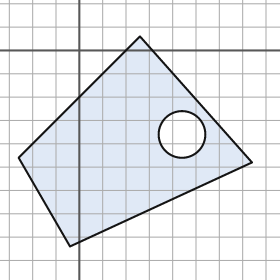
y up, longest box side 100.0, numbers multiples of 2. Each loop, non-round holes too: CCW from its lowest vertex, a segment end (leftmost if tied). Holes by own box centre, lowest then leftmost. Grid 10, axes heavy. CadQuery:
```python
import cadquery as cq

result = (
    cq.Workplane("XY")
    .moveTo(-4.0, -84.0)
    .lineTo(74.0, -48.0)
    .lineTo(26.0, 6.0)
    .lineTo(-26.0, -46.0)
    .close()
    .moveTo(44.0, -36.0)
    .circle(10.0)
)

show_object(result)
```